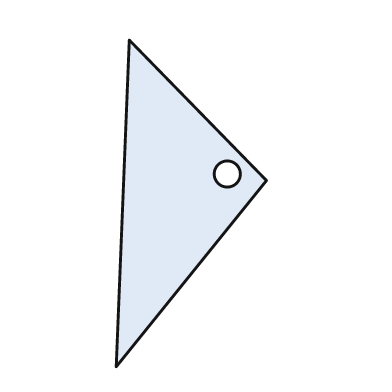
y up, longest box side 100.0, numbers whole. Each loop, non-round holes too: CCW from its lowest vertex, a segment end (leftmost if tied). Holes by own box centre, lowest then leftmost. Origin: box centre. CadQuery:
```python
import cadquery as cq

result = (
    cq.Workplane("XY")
    .moveTo(-23.0, -50.0)
    .lineTo(23.0, 7.0)
    .lineTo(-19.0, 50.0)
    .close()
    .moveTo(11.0, 9.0)
    .circle(4.0)
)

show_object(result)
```